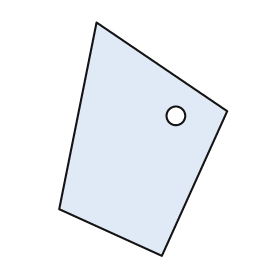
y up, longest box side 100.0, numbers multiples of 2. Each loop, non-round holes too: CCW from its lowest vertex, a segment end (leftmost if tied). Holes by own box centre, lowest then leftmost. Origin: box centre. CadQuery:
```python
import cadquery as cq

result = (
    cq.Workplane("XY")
    .moveTo(8.0, -50.0)
    .lineTo(36.0, 12.0)
    .lineTo(-20.0, 50.0)
    .lineTo(-36.0, -30.0)
    .close()
    .moveTo(14.0, 10.0)
    .circle(4.0)
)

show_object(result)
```